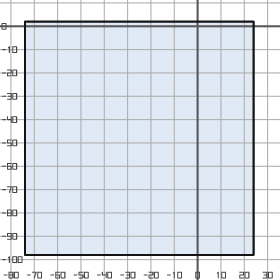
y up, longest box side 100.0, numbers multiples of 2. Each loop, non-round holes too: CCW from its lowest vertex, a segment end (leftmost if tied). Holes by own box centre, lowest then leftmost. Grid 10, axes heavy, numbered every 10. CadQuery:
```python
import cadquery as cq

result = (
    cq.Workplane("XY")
    .moveTo(-74.0, -98.0)
    .lineTo(24.0, -98.0)
    .lineTo(24.0, 2.0)
    .lineTo(-74.0, 2.0)
    .close()
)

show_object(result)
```